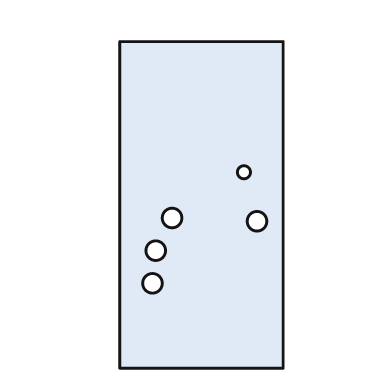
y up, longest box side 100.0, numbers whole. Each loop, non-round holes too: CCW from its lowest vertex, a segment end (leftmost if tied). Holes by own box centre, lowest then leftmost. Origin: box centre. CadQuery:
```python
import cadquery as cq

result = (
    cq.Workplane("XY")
    .moveTo(-25.0, -50.0)
    .lineTo(25.0, -50.0)
    .lineTo(25.0, 50.0)
    .lineTo(-25.0, 50.0)
    .close()
    .moveTo(-15.0, -24.0)
    .circle(3.0)
    .moveTo(-14.0, -14.0)
    .circle(3.0)
    .moveTo(17.0, -5.0)
    .circle(3.0)
    .moveTo(-9.0, -4.0)
    .circle(3.0)
    .moveTo(13.0, 10.0)
    .circle(2.0)
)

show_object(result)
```